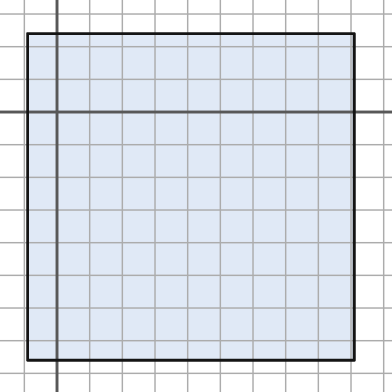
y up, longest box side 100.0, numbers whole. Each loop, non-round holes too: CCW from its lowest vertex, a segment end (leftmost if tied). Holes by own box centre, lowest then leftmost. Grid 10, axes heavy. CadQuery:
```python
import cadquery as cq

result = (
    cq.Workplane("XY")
    .moveTo(-9.0, -76.0)
    .lineTo(91.0, -76.0)
    .lineTo(91.0, 24.0)
    .lineTo(-9.0, 24.0)
    .close()
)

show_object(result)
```